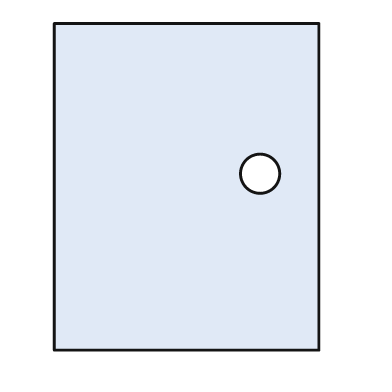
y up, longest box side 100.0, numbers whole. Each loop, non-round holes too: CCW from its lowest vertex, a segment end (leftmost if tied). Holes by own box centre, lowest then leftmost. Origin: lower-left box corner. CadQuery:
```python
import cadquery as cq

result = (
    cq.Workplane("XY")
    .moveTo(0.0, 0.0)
    .lineTo(81.0, 0.0)
    .lineTo(81.0, 100.0)
    .lineTo(0.0, 100.0)
    .close()
    .moveTo(63.0, 54.0)
    .circle(6.0)
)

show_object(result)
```